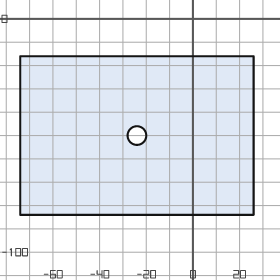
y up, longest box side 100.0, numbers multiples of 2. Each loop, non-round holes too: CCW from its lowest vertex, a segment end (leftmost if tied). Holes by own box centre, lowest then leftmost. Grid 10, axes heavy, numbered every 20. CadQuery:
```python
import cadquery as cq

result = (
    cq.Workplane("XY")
    .moveTo(-74.0, -84.0)
    .lineTo(26.0, -84.0)
    .lineTo(26.0, -16.0)
    .lineTo(-74.0, -16.0)
    .close()
    .moveTo(-24.0, -50.0)
    .circle(4.0)
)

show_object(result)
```